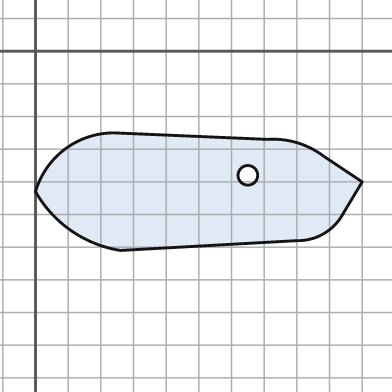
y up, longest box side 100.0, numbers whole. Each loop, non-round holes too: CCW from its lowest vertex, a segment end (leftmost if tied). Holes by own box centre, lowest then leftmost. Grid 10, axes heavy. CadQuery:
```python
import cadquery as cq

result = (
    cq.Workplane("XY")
    .moveTo(26.0, -61.0)
    .lineTo(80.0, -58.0)
    .threePointArc((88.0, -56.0), (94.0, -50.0))
    .lineTo(100.0, -40.0)
    .lineTo(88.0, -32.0)
    .threePointArc((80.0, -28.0), (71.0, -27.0))
    .lineTo(24.0, -25.0)
    .threePointArc((9.0, -30.0), (0.0, -43.0))
    .threePointArc((11.0, -55.0), (26.0, -61.0))
    .close()
    .moveTo(65.0, -38.0)
    .circle(3.0)
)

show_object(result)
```